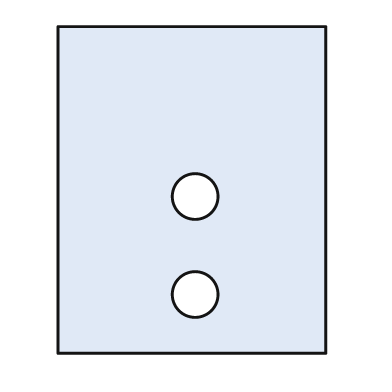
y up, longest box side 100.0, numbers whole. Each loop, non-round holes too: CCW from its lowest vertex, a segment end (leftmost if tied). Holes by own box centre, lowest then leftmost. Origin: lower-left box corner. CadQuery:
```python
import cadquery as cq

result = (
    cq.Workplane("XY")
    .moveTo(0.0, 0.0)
    .lineTo(82.0, 0.0)
    .lineTo(82.0, 100.0)
    .lineTo(0.0, 100.0)
    .close()
    .moveTo(42.0, 18.0)
    .circle(7.0)
    .moveTo(42.0, 48.0)
    .circle(7.0)
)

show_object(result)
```